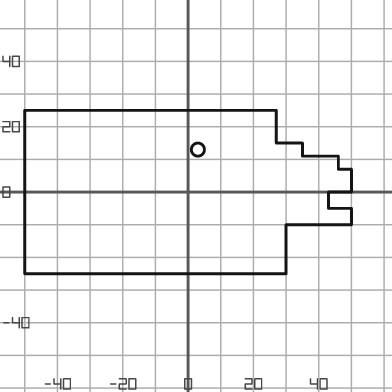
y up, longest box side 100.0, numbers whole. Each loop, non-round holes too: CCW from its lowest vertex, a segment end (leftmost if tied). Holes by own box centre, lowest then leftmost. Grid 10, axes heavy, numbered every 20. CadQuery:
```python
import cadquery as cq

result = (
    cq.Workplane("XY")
    .moveTo(-50.0, -25.0)
    .lineTo(30.0, -25.0)
    .lineTo(30.0, -10.0)
    .lineTo(50.0, -10.0)
    .lineTo(50.0, -5.0)
    .lineTo(43.0, -5.0)
    .lineTo(43.0, 0.0)
    .lineTo(50.0, 0.0)
    .lineTo(50.0, 7.0)
    .lineTo(46.0, 7.0)
    .lineTo(46.0, 11.0)
    .lineTo(35.0, 11.0)
    .lineTo(35.0, 15.0)
    .lineTo(27.0, 15.0)
    .lineTo(27.0, 25.0)
    .lineTo(-50.0, 25.0)
    .close()
    .moveTo(3.0, 13.0)
    .circle(2.0)
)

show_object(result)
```